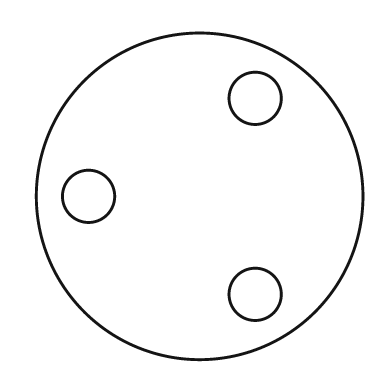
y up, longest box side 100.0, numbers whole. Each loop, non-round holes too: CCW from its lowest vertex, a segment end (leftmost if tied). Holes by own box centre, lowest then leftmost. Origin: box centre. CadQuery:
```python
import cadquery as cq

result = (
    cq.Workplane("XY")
    .moveTo(0.0, 0.0)
    .circle(50.0)
    .moveTo(17.0, -30.0)
    .circle(8.0)
    .moveTo(-34.0, 0.0)
    .circle(8.0)
    .moveTo(17.0, 30.0)
    .circle(8.0)
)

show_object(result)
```